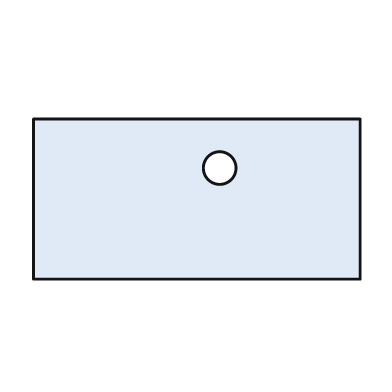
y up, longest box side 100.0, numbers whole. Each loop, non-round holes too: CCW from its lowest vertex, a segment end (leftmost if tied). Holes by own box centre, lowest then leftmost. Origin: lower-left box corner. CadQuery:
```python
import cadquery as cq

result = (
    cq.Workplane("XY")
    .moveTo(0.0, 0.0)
    .lineTo(100.0, 0.0)
    .lineTo(100.0, 49.0)
    .lineTo(0.0, 49.0)
    .close()
    .moveTo(57.0, 34.0)
    .circle(5.0)
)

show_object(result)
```